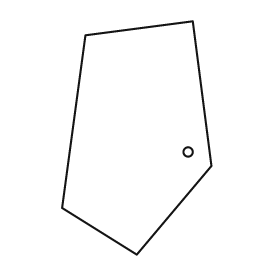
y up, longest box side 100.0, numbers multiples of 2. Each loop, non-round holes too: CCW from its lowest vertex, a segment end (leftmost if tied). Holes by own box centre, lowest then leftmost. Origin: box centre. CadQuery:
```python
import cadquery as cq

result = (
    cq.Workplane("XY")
    .moveTo(0.0, -50.0)
    .lineTo(32.0, -12.0)
    .lineTo(24.0, 50.0)
    .lineTo(-22.0, 44.0)
    .lineTo(-32.0, -30.0)
    .close()
    .moveTo(22.0, -6.0)
    .circle(2.0)
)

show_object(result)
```